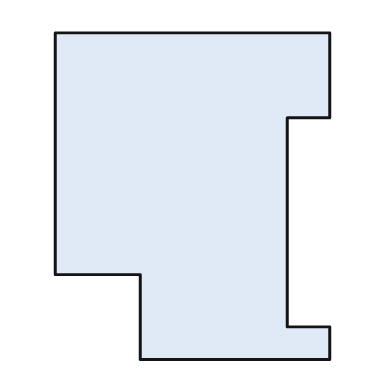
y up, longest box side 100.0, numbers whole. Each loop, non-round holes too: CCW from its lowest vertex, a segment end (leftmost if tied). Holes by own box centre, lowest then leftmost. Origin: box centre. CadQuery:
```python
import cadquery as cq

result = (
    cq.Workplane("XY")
    .moveTo(-16.0, -50.0)
    .lineTo(42.0, -50.0)
    .lineTo(42.0, -40.0)
    .lineTo(29.0, -40.0)
    .lineTo(29.0, 24.0)
    .lineTo(42.0, 24.0)
    .lineTo(42.0, 50.0)
    .lineTo(-42.0, 50.0)
    .lineTo(-42.0, -24.0)
    .lineTo(-16.0, -24.0)
    .close()
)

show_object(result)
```